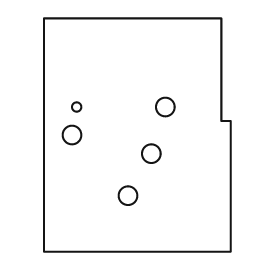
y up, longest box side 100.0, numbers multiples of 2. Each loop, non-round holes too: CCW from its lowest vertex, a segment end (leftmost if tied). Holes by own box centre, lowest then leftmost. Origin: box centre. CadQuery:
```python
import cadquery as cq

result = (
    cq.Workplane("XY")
    .moveTo(-40.0, -50.0)
    .lineTo(40.0, -50.0)
    .lineTo(40.0, 6.0)
    .lineTo(36.0, 6.0)
    .lineTo(36.0, 50.0)
    .lineTo(-40.0, 50.0)
    .close()
    .moveTo(-4.0, -26.0)
    .circle(4.0)
    .moveTo(6.0, -8.0)
    .circle(4.0)
    .moveTo(-28.0, 0.0)
    .circle(4.0)
    .moveTo(-26.0, 12.0)
    .circle(2.0)
    .moveTo(12.0, 12.0)
    .circle(4.0)
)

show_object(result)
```